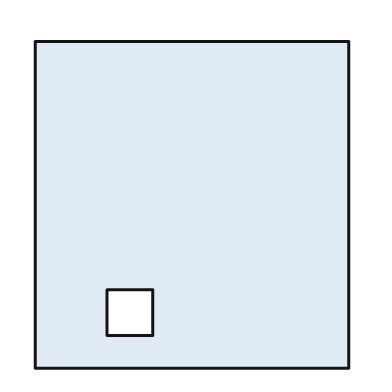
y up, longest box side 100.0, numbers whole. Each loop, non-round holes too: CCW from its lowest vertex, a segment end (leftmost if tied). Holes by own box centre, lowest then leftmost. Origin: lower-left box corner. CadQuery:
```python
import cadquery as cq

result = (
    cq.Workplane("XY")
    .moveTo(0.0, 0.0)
    .lineTo(96.0, 0.0)
    .lineTo(96.0, 100.0)
    .lineTo(0.0, 100.0)
    .close()
    .moveTo(22.0, 10.0)
    .lineTo(36.0, 10.0)
    .lineTo(36.0, 24.0)
    .lineTo(22.0, 24.0)
    .close()
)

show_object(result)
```